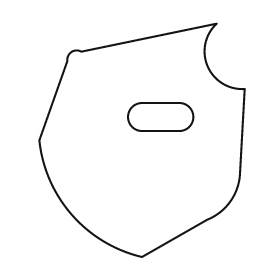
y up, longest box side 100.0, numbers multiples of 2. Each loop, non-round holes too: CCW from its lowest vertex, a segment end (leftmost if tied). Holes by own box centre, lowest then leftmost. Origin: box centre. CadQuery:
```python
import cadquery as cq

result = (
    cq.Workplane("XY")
    .moveTo(0.0, -50.0)
    .lineTo(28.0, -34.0)
    .threePointArc((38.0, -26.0), (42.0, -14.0))
    .lineTo(44.0, 22.0)
    .threePointArc((28.0, 32.0), (32.0, 50.0))
    .lineTo(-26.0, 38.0)
    .threePointArc((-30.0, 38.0), (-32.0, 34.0))
    .lineTo(-44.0, 0.0)
    .threePointArc((-30.0, -32.0), (0.0, -50.0))
    .close()
    .moveTo(0.0, 4.0)
    .lineTo(16.0, 4.0)
    .threePointArc((22.0, 10.0), (16.0, 16.0))
    .lineTo(0.0, 16.0)
    .threePointArc((-6.0, 10.0), (0.0, 4.0))
    .close()
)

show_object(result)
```